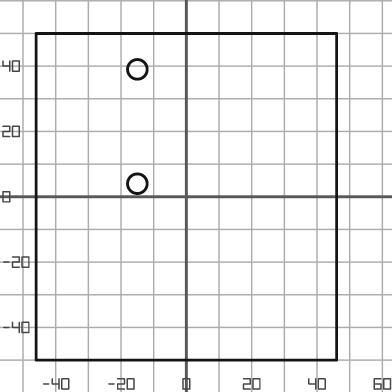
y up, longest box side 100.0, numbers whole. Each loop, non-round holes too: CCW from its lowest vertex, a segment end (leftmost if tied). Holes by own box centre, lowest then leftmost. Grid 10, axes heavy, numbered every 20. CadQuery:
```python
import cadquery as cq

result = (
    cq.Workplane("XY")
    .moveTo(-46.0, -50.0)
    .lineTo(46.0, -50.0)
    .lineTo(46.0, 50.0)
    .lineTo(-46.0, 50.0)
    .close()
    .moveTo(-15.0, 4.0)
    .circle(3.0)
    .moveTo(-15.0, 39.0)
    .circle(3.0)
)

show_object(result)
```